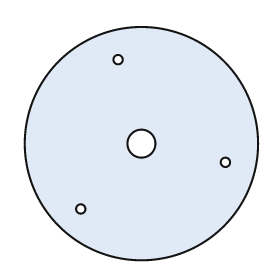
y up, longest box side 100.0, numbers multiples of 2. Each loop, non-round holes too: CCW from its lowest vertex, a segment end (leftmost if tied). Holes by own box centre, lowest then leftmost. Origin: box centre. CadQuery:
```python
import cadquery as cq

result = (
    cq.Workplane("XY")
    .moveTo(0.0, 0.0)
    .circle(50.0)
    .moveTo(-26.0, -28.0)
    .circle(2.0)
    .moveTo(36.0, -8.0)
    .circle(2.0)
    .moveTo(0.0, 0.0)
    .circle(6.0)
    .moveTo(-10.0, 36.0)
    .circle(2.0)
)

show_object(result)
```